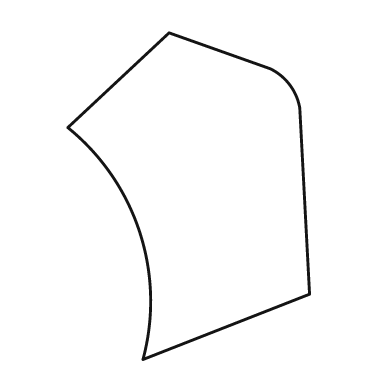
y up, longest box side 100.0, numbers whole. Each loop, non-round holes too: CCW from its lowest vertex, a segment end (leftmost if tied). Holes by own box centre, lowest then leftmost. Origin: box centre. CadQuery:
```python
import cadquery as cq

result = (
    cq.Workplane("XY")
    .moveTo(-14.0, -50.0)
    .lineTo(37.0, -30.0)
    .lineTo(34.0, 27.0)
    .threePointArc((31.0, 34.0), (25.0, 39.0))
    .lineTo(-6.0, 50.0)
    .lineTo(-37.0, 21.0)
    .threePointArc((-15.0, -11.0), (-14.0, -50.0))
    .close()
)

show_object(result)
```